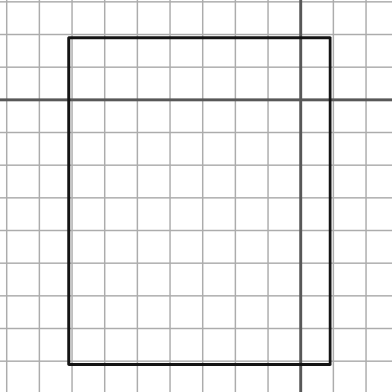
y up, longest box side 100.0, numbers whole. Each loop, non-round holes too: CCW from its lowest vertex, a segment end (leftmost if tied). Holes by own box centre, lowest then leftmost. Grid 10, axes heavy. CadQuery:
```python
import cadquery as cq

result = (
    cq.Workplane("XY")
    .moveTo(-71.0, -81.0)
    .lineTo(9.0, -81.0)
    .lineTo(9.0, 19.0)
    .lineTo(-71.0, 19.0)
    .close()
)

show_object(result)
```